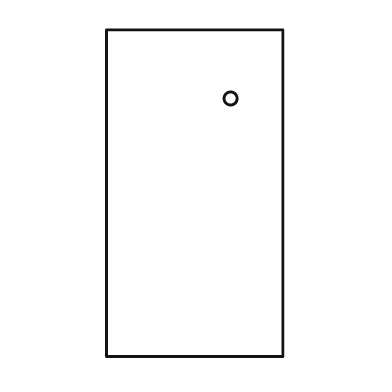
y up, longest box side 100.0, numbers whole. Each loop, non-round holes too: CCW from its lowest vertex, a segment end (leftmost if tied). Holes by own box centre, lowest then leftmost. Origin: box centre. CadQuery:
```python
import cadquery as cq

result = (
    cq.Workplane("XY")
    .moveTo(-27.0, -50.0)
    .lineTo(27.0, -50.0)
    .lineTo(27.0, 50.0)
    .lineTo(-27.0, 50.0)
    .close()
    .moveTo(11.0, 29.0)
    .circle(2.0)
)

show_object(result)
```